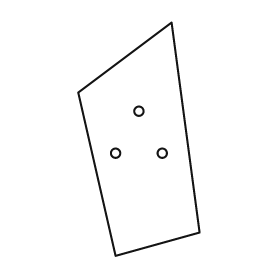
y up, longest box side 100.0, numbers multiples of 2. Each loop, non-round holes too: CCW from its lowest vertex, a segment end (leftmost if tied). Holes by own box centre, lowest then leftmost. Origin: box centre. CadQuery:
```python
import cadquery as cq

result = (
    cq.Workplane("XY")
    .moveTo(-10.0, -50.0)
    .lineTo(26.0, -40.0)
    .lineTo(14.0, 50.0)
    .lineTo(-26.0, 20.0)
    .close()
    .moveTo(-10.0, -6.0)
    .circle(2.0)
    .moveTo(10.0, -6.0)
    .circle(2.0)
    .moveTo(0.0, 12.0)
    .circle(2.0)
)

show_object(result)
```